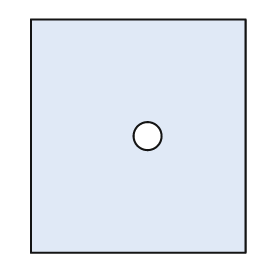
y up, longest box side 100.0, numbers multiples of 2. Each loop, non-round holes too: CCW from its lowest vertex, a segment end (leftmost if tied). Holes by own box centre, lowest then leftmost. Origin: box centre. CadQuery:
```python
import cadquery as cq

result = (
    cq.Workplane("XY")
    .moveTo(-46.0, -50.0)
    .lineTo(46.0, -50.0)
    .lineTo(46.0, 50.0)
    .lineTo(-46.0, 50.0)
    .close()
    .moveTo(4.0, 0.0)
    .circle(6.0)
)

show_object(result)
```